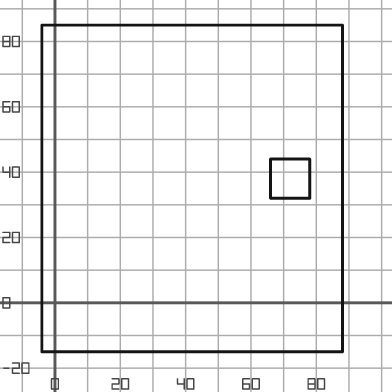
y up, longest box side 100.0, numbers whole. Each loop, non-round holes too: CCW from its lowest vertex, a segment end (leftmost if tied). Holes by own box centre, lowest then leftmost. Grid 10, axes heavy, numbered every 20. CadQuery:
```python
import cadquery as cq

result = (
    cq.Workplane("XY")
    .moveTo(-4.0, -15.0)
    .lineTo(88.0, -15.0)
    .lineTo(88.0, 85.0)
    .lineTo(-4.0, 85.0)
    .close()
    .moveTo(66.0, 32.0)
    .lineTo(78.0, 32.0)
    .lineTo(78.0, 44.0)
    .lineTo(66.0, 44.0)
    .close()
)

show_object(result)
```